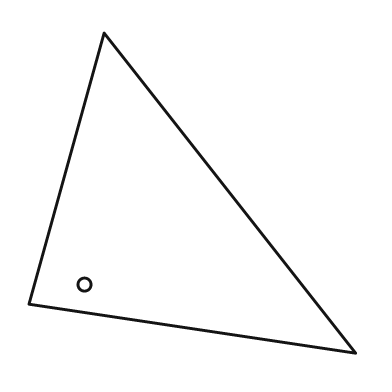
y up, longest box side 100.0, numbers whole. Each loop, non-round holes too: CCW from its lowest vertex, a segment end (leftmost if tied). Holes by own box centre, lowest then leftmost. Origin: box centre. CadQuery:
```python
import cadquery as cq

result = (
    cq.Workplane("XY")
    .moveTo(50.0, -49.0)
    .lineTo(-27.0, 49.0)
    .lineTo(-50.0, -34.0)
    .close()
    .moveTo(-33.0, -28.0)
    .circle(2.0)
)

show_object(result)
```